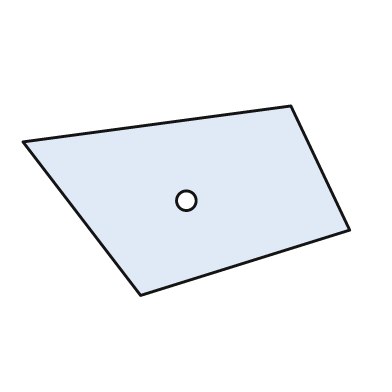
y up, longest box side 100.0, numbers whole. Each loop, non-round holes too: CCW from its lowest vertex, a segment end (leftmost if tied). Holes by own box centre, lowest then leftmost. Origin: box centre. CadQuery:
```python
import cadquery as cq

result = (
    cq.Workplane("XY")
    .moveTo(-14.0, -29.0)
    .lineTo(50.0, -9.0)
    .lineTo(32.0, 29.0)
    .lineTo(-50.0, 18.0)
    .close()
    .moveTo(0.0, 0.0)
    .circle(3.0)
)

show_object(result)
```